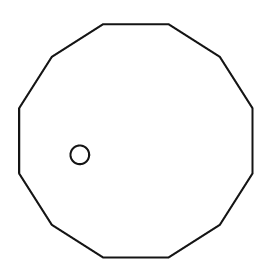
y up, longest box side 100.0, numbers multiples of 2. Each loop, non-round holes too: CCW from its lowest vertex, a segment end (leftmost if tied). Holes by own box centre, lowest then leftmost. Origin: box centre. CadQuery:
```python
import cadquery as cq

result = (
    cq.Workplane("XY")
    .moveTo(-14.0, -50.0)
    .lineTo(14.0, -50.0)
    .lineTo(36.0, -36.0)
    .lineTo(50.0, -14.0)
    .lineTo(50.0, 14.0)
    .lineTo(36.0, 36.0)
    .lineTo(14.0, 50.0)
    .lineTo(-14.0, 50.0)
    .lineTo(-36.0, 36.0)
    .lineTo(-50.0, 14.0)
    .lineTo(-50.0, -14.0)
    .lineTo(-36.0, -36.0)
    .close()
    .moveTo(-24.0, -6.0)
    .circle(4.0)
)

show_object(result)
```